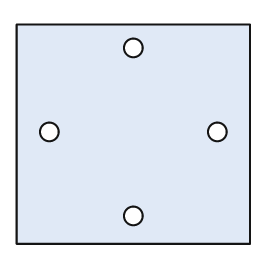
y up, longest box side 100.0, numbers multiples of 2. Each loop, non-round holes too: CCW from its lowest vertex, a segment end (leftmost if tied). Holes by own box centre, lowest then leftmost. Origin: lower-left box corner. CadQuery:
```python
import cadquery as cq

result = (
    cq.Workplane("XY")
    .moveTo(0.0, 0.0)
    .lineTo(100.0, 0.0)
    .lineTo(100.0, 94.0)
    .lineTo(0.0, 94.0)
    .close()
    .moveTo(50.0, 12.0)
    .circle(4.0)
    .moveTo(14.0, 48.0)
    .circle(4.0)
    .moveTo(86.0, 48.0)
    .circle(4.0)
    .moveTo(50.0, 84.0)
    .circle(4.0)
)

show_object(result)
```